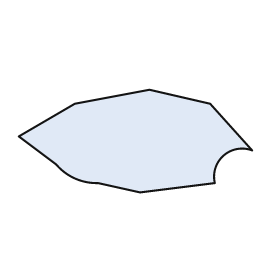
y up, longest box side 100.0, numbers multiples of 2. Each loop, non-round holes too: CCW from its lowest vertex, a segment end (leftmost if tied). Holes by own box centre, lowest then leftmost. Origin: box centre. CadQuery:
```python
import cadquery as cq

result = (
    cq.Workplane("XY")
    .moveTo(2.0, -22.0)
    .lineTo(34.0, -18.0)
    .threePointArc((38.0, -6.0), (50.0, -4.0))
    .lineTo(32.0, 16.0)
    .lineTo(6.0, 22.0)
    .lineTo(-26.0, 16.0)
    .lineTo(-50.0, 2.0)
    .lineTo(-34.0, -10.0)
    .threePointArc((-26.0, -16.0), (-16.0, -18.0))
    .close()
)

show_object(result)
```